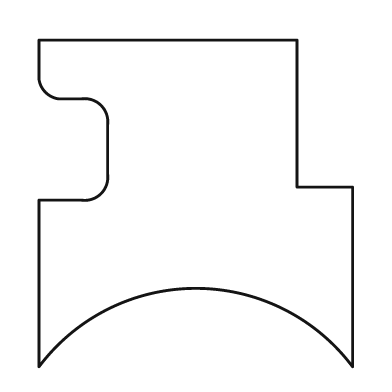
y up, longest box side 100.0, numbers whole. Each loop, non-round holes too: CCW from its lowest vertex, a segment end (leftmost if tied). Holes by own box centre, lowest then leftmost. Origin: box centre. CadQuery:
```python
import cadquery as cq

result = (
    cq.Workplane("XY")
    .moveTo(-48.0, -50.0)
    .threePointArc((0.0, -26.0), (48.0, -50.0))
    .lineTo(48.0, 5.0)
    .lineTo(31.0, 5.0)
    .lineTo(31.0, 50.0)
    .lineTo(-48.0, 50.0)
    .lineTo(-48.0, 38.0)
    .threePointArc((-46.0, 34.0), (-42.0, 32.0))
    .lineTo(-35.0, 32.0)
    .threePointArc((-29.0, 30.0), (-27.0, 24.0))
    .lineTo(-27.0, 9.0)
    .threePointArc((-29.0, 3.0), (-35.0, 1.0))
    .lineTo(-48.0, 1.0)
    .close()
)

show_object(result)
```